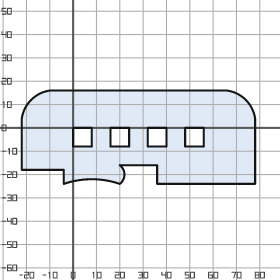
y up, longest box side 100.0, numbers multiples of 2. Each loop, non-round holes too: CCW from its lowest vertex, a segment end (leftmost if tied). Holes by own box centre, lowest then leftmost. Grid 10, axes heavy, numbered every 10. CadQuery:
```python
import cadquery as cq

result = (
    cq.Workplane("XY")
    .moveTo(-4.0, -24.0)
    .threePointArc((8.0, -22.0), (20.0, -24.0))
    .threePointArc((22.0, -20.0), (20.0, -16.0))
    .lineTo(36.0, -16.0)
    .lineTo(36.0, -24.0)
    .lineTo(78.0, -24.0)
    .lineTo(78.0, 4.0)
    .threePointArc((74.0, 12.0), (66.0, 16.0))
    .lineTo(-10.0, 16.0)
    .threePointArc((-18.0, 12.0), (-22.0, 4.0))
    .lineTo(-22.0, -18.0)
    .lineTo(-4.0, -18.0)
    .close()
    .moveTo(0.0, -8.0)
    .lineTo(8.0, -8.0)
    .lineTo(8.0, 0.0)
    .lineTo(0.0, 0.0)
    .close()
    .moveTo(16.0, -8.0)
    .lineTo(24.0, -8.0)
    .lineTo(24.0, 0.0)
    .lineTo(16.0, 0.0)
    .close()
    .moveTo(32.0, -8.0)
    .lineTo(40.0, -8.0)
    .lineTo(40.0, 0.0)
    .lineTo(32.0, 0.0)
    .close()
    .moveTo(48.0, -8.0)
    .lineTo(56.0, -8.0)
    .lineTo(56.0, 0.0)
    .lineTo(48.0, 0.0)
    .close()
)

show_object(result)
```